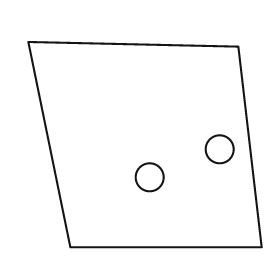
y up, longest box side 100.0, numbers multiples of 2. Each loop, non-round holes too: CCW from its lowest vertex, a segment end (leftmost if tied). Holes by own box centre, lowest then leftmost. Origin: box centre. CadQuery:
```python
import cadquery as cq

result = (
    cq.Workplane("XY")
    .moveTo(-32.0, -44.0)
    .lineTo(50.0, -44.0)
    .lineTo(40.0, 42.0)
    .lineTo(-50.0, 44.0)
    .close()
    .moveTo(2.0, -14.0)
    .circle(6.0)
    .moveTo(32.0, -2.0)
    .circle(6.0)
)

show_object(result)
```